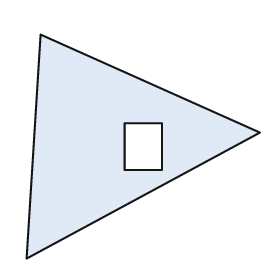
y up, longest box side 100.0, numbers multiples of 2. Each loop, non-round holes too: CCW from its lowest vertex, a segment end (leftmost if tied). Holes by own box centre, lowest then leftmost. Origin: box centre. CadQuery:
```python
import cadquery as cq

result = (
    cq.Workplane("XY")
    .moveTo(-50.0, -48.0)
    .lineTo(50.0, 6.0)
    .lineTo(-44.0, 48.0)
    .close()
    .moveTo(-8.0, -10.0)
    .lineTo(8.0, -10.0)
    .lineTo(8.0, 10.0)
    .lineTo(-8.0, 10.0)
    .close()
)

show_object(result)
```